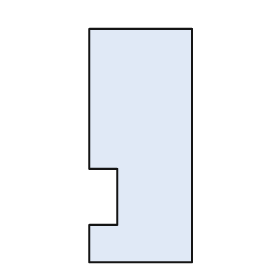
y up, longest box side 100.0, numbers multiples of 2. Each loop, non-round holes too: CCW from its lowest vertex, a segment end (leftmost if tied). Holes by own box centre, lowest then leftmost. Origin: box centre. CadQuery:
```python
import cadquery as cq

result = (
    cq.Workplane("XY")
    .moveTo(-22.0, -50.0)
    .lineTo(22.0, -50.0)
    .lineTo(22.0, 50.0)
    .lineTo(-22.0, 50.0)
    .lineTo(-22.0, -10.0)
    .lineTo(-10.0, -10.0)
    .lineTo(-10.0, -34.0)
    .lineTo(-22.0, -34.0)
    .close()
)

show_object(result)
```